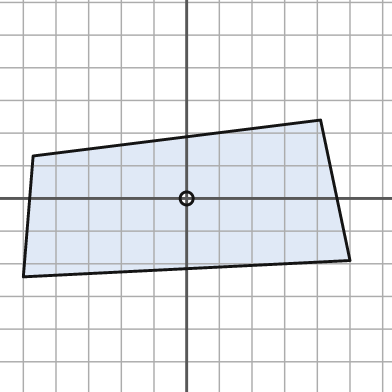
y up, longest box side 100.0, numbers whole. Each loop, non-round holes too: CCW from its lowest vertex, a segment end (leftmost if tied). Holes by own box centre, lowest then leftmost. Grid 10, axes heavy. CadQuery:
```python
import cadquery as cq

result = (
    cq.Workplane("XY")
    .moveTo(-50.0, -24.0)
    .lineTo(50.0, -19.0)
    .lineTo(41.0, 24.0)
    .lineTo(-47.0, 13.0)
    .close()
    .moveTo(0.0, 0.0)
    .circle(2.0)
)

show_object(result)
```